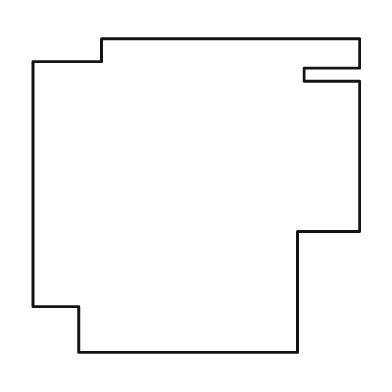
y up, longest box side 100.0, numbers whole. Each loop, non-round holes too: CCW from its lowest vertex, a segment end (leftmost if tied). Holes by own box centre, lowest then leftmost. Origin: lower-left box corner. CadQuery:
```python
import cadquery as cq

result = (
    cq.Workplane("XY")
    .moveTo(14.0, 0.0)
    .lineTo(81.0, 0.0)
    .lineTo(81.0, 37.0)
    .lineTo(100.0, 37.0)
    .lineTo(100.0, 83.0)
    .lineTo(83.0, 83.0)
    .lineTo(83.0, 87.0)
    .lineTo(100.0, 87.0)
    .lineTo(100.0, 96.0)
    .lineTo(21.0, 96.0)
    .lineTo(21.0, 89.0)
    .lineTo(0.0, 89.0)
    .lineTo(0.0, 14.0)
    .lineTo(14.0, 14.0)
    .close()
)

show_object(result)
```